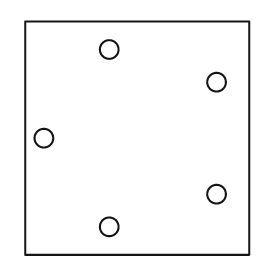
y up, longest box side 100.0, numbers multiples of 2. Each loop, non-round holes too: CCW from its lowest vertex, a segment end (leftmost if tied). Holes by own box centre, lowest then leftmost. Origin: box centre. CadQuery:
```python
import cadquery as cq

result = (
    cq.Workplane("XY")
    .moveTo(-48.0, -50.0)
    .lineTo(48.0, -50.0)
    .lineTo(48.0, 50.0)
    .lineTo(-48.0, 50.0)
    .close()
    .moveTo(-12.0, -38.0)
    .circle(4.0)
    .moveTo(34.0, -24.0)
    .circle(4.0)
    .moveTo(-40.0, 0.0)
    .circle(4.0)
    .moveTo(34.0, 24.0)
    .circle(4.0)
    .moveTo(-12.0, 38.0)
    .circle(4.0)
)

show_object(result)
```